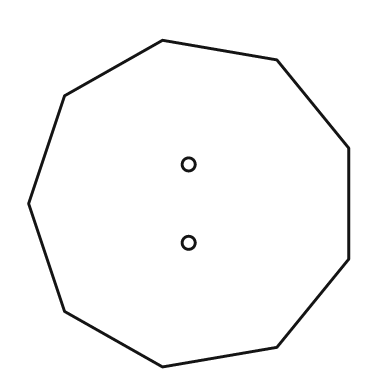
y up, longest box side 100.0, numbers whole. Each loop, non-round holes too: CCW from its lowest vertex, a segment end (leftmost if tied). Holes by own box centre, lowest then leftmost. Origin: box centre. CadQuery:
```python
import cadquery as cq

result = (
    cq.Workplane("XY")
    .moveTo(-8.0, -50.0)
    .lineTo(27.0, -44.0)
    .lineTo(49.0, -17.0)
    .lineTo(49.0, 17.0)
    .lineTo(27.0, 44.0)
    .lineTo(-8.0, 50.0)
    .lineTo(-38.0, 33.0)
    .lineTo(-49.0, 0.0)
    .lineTo(-38.0, -33.0)
    .close()
    .moveTo(0.0, -12.0)
    .circle(2.0)
    .moveTo(0.0, 12.0)
    .circle(2.0)
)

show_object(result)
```